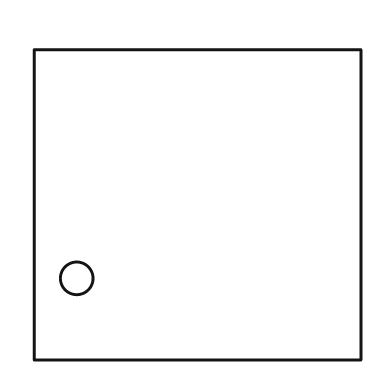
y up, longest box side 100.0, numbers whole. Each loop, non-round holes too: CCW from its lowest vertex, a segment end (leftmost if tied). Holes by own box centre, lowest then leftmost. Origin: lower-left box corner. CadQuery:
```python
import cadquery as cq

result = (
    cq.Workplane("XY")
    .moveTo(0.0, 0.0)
    .lineTo(100.0, 0.0)
    .lineTo(100.0, 95.0)
    .lineTo(0.0, 95.0)
    .close()
    .moveTo(13.0, 25.0)
    .circle(5.0)
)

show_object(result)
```